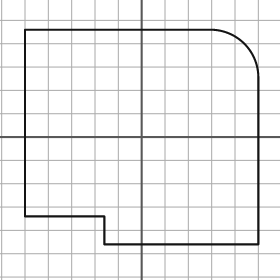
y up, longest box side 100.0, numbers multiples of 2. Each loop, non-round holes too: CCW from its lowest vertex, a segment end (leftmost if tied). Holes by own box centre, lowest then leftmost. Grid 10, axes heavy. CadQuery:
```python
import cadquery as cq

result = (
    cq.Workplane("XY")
    .moveTo(-16.0, -46.0)
    .lineTo(50.0, -46.0)
    .lineTo(50.0, 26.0)
    .threePointArc((44.0, 40.0), (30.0, 46.0))
    .lineTo(-50.0, 46.0)
    .lineTo(-50.0, -34.0)
    .lineTo(-16.0, -34.0)
    .close()
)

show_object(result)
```